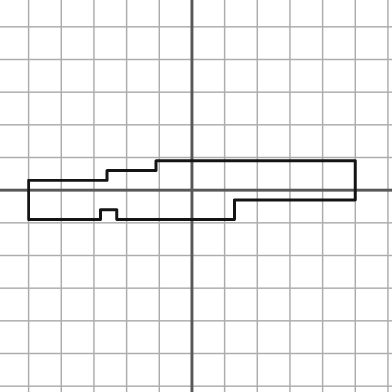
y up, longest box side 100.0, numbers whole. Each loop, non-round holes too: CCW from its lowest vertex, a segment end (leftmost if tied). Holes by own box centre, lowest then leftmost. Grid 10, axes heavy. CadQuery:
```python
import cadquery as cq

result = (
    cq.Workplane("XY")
    .moveTo(-50.0, -9.0)
    .lineTo(-28.0, -9.0)
    .lineTo(-28.0, -6.0)
    .lineTo(-23.0, -6.0)
    .lineTo(-23.0, -9.0)
    .lineTo(13.0, -9.0)
    .lineTo(13.0, -3.0)
    .lineTo(50.0, -3.0)
    .lineTo(50.0, 9.0)
    .lineTo(-11.0, 9.0)
    .lineTo(-11.0, 6.0)
    .lineTo(-26.0, 6.0)
    .lineTo(-26.0, 3.0)
    .lineTo(-50.0, 3.0)
    .close()
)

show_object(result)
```